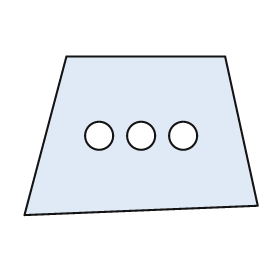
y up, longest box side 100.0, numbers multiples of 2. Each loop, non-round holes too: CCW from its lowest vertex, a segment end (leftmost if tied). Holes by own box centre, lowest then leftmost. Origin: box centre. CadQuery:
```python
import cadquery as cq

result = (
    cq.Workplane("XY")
    .moveTo(-50.0, -34.0)
    .lineTo(50.0, -30.0)
    .lineTo(36.0, 34.0)
    .lineTo(-32.0, 34.0)
    .close()
    .moveTo(-18.0, 0.0)
    .circle(6.0)
    .moveTo(0.0, 0.0)
    .circle(6.0)
    .moveTo(18.0, 0.0)
    .circle(6.0)
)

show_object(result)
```